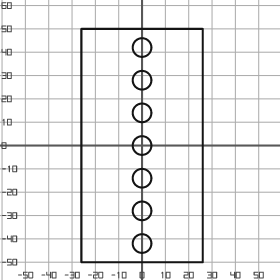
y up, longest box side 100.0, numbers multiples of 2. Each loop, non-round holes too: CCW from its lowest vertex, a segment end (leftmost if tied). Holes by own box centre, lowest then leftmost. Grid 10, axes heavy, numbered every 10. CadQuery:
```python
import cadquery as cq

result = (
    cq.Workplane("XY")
    .moveTo(-26.0, -50.0)
    .lineTo(26.0, -50.0)
    .lineTo(26.0, 50.0)
    .lineTo(-26.0, 50.0)
    .close()
    .moveTo(0.0, -42.0)
    .circle(4.0)
    .moveTo(0.0, -28.0)
    .circle(4.0)
    .moveTo(0.0, -14.0)
    .circle(4.0)
    .moveTo(0.0, 0.0)
    .circle(4.0)
    .moveTo(0.0, 14.0)
    .circle(4.0)
    .moveTo(0.0, 28.0)
    .circle(4.0)
    .moveTo(0.0, 42.0)
    .circle(4.0)
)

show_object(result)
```